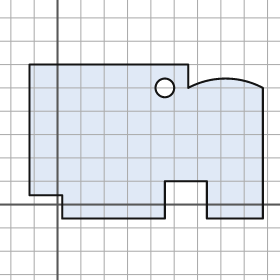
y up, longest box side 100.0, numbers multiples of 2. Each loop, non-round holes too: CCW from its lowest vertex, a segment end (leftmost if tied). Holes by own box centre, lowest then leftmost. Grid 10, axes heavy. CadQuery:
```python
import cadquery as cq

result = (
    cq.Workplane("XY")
    .moveTo(2.0, -6.0)
    .lineTo(46.0, -6.0)
    .lineTo(46.0, 10.0)
    .lineTo(64.0, 10.0)
    .lineTo(64.0, -6.0)
    .lineTo(88.0, -6.0)
    .lineTo(88.0, 50.0)
    .threePointArc((72.0, 54.0), (56.0, 50.0))
    .lineTo(56.0, 60.0)
    .lineTo(-12.0, 60.0)
    .lineTo(-12.0, 4.0)
    .lineTo(2.0, 4.0)
    .close()
    .moveTo(46.0, 50.0)
    .circle(4.0)
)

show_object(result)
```